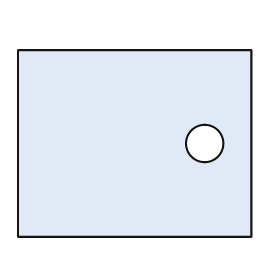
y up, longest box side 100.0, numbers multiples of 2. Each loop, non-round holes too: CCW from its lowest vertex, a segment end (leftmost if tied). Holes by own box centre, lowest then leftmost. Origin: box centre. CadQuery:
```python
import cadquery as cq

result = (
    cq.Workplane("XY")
    .moveTo(-50.0, -40.0)
    .lineTo(50.0, -40.0)
    .lineTo(50.0, 40.0)
    .lineTo(-50.0, 40.0)
    .close()
    .moveTo(30.0, 0.0)
    .circle(8.0)
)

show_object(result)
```